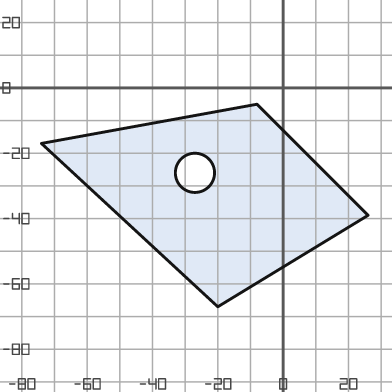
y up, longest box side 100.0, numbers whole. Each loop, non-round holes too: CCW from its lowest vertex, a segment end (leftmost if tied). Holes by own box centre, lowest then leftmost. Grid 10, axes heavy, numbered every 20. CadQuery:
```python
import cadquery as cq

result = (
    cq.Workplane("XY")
    .moveTo(-20.0, -67.0)
    .lineTo(26.0, -39.0)
    .lineTo(-8.0, -5.0)
    .lineTo(-74.0, -17.0)
    .close()
    .moveTo(-27.0, -26.0)
    .circle(6.0)
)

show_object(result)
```